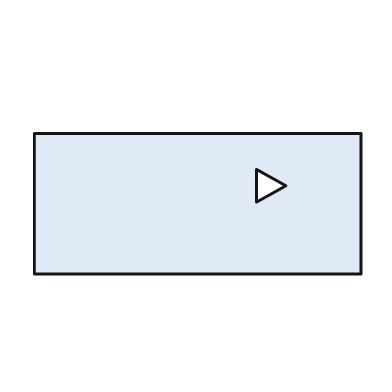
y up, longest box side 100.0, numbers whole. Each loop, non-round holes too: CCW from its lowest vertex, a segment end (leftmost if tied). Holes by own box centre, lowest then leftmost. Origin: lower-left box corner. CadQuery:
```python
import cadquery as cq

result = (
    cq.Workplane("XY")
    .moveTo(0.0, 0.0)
    .lineTo(100.0, 0.0)
    .lineTo(100.0, 43.0)
    .lineTo(0.0, 43.0)
    .close()
    .moveTo(68.0, 22.0)
    .lineTo(77.0, 27.0)
    .lineTo(68.0, 32.0)
    .close()
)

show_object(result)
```